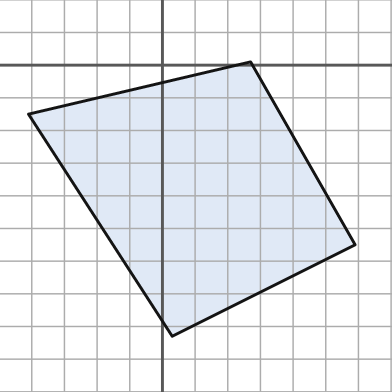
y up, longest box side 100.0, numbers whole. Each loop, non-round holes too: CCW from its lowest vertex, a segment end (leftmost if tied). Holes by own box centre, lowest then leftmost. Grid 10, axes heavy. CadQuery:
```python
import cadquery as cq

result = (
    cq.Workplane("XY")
    .moveTo(3.0, -83.0)
    .lineTo(59.0, -55.0)
    .lineTo(27.0, 1.0)
    .lineTo(-41.0, -15.0)
    .close()
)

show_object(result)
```